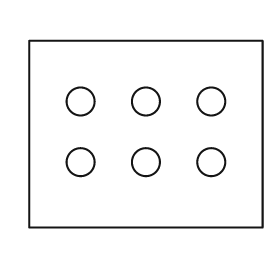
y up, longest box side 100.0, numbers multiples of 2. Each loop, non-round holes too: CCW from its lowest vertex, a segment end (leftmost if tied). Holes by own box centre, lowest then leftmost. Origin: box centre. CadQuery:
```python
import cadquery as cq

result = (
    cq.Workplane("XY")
    .moveTo(-50.0, -40.0)
    .lineTo(50.0, -40.0)
    .lineTo(50.0, 40.0)
    .lineTo(-50.0, 40.0)
    .close()
    .moveTo(-28.0, -12.0)
    .circle(6.0)
    .moveTo(0.0, -12.0)
    .circle(6.0)
    .moveTo(28.0, -12.0)
    .circle(6.0)
    .moveTo(-28.0, 14.0)
    .circle(6.0)
    .moveTo(0.0, 14.0)
    .circle(6.0)
    .moveTo(28.0, 14.0)
    .circle(6.0)
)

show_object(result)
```